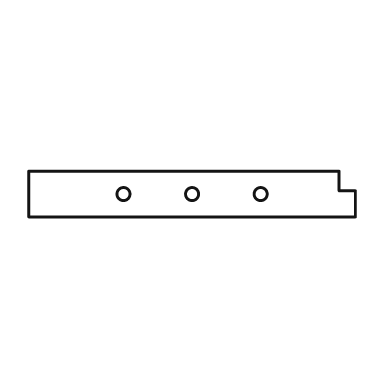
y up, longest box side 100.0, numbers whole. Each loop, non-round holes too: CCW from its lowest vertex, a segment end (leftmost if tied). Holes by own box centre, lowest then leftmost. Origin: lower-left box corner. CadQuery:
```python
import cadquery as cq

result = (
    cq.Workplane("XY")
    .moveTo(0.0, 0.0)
    .lineTo(100.0, 0.0)
    .lineTo(100.0, 8.0)
    .lineTo(95.0, 8.0)
    .lineTo(95.0, 14.0)
    .lineTo(0.0, 14.0)
    .close()
    .moveTo(29.0, 7.0)
    .circle(2.0)
    .moveTo(50.0, 7.0)
    .circle(2.0)
    .moveTo(71.0, 7.0)
    .circle(2.0)
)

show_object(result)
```